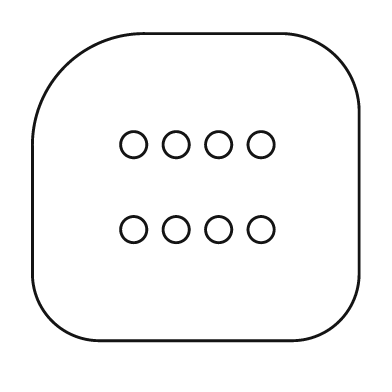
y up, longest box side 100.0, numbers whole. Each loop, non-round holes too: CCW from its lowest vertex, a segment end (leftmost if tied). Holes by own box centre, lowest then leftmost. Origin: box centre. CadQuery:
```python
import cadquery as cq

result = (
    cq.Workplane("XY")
    .moveTo(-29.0, -47.0)
    .lineTo(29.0, -47.0)
    .threePointArc((44.0, -41.0), (50.0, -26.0))
    .lineTo(50.0, 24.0)
    .threePointArc((43.0, 40.0), (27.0, 47.0))
    .lineTo(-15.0, 47.0)
    .threePointArc((-40.0, 37.0), (-50.0, 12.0))
    .lineTo(-50.0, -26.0)
    .threePointArc((-44.0, -41.0), (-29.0, -47.0))
    .close()
    .moveTo(-19.0, -13.0)
    .circle(4.0)
    .moveTo(-6.0, -13.0)
    .circle(4.0)
    .moveTo(7.0, -13.0)
    .circle(4.0)
    .moveTo(20.0, -13.0)
    .circle(4.0)
    .moveTo(-19.0, 13.0)
    .circle(4.0)
    .moveTo(-6.0, 13.0)
    .circle(4.0)
    .moveTo(7.0, 13.0)
    .circle(4.0)
    .moveTo(20.0, 13.0)
    .circle(4.0)
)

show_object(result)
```